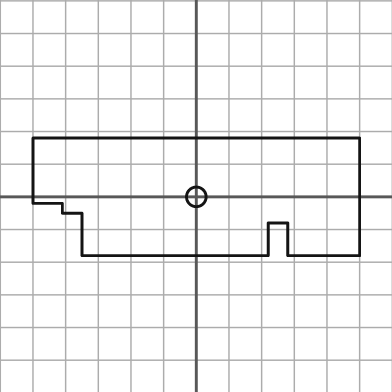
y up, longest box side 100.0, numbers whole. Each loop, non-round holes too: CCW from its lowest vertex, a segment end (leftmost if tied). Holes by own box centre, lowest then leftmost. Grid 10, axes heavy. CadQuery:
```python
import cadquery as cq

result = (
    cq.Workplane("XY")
    .moveTo(-35.0, -18.0)
    .lineTo(22.0, -18.0)
    .lineTo(22.0, -8.0)
    .lineTo(28.0, -8.0)
    .lineTo(28.0, -18.0)
    .lineTo(50.0, -18.0)
    .lineTo(50.0, 18.0)
    .lineTo(-50.0, 18.0)
    .lineTo(-50.0, -2.0)
    .lineTo(-41.0, -2.0)
    .lineTo(-41.0, -5.0)
    .lineTo(-35.0, -5.0)
    .close()
    .moveTo(0.0, 0.0)
    .circle(3.0)
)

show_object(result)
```